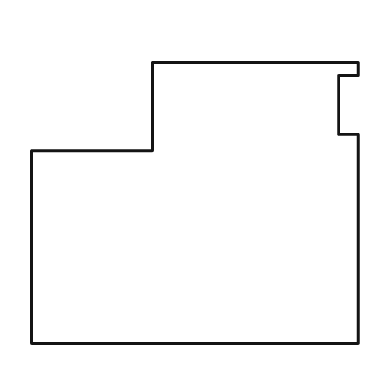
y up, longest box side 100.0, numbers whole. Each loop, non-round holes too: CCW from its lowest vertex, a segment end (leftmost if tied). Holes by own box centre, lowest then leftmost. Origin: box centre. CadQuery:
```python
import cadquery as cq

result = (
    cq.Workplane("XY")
    .moveTo(-50.0, -43.0)
    .lineTo(50.0, -43.0)
    .lineTo(50.0, 21.0)
    .lineTo(44.0, 21.0)
    .lineTo(44.0, 39.0)
    .lineTo(50.0, 39.0)
    .lineTo(50.0, 43.0)
    .lineTo(-13.0, 43.0)
    .lineTo(-13.0, 16.0)
    .lineTo(-50.0, 16.0)
    .close()
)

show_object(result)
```